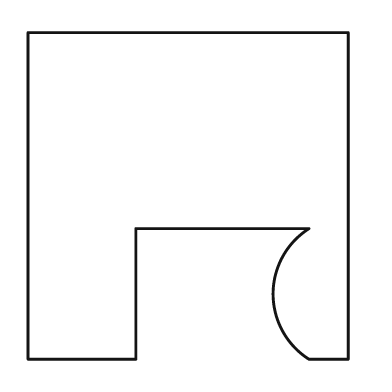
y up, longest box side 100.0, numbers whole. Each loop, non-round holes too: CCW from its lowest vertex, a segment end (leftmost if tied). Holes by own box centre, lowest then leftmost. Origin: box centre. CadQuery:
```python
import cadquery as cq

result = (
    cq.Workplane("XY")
    .moveTo(-49.0, -50.0)
    .lineTo(-16.0, -50.0)
    .lineTo(-16.0, -10.0)
    .lineTo(37.0, -10.0)
    .threePointArc((26.0, -30.0), (37.0, -50.0))
    .lineTo(49.0, -50.0)
    .lineTo(49.0, 50.0)
    .lineTo(-49.0, 50.0)
    .close()
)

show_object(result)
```